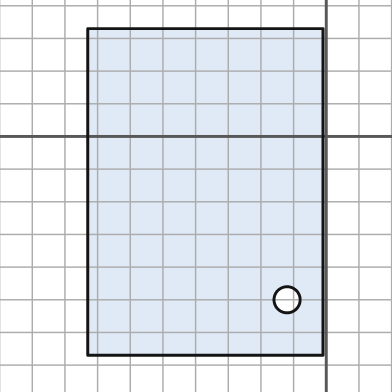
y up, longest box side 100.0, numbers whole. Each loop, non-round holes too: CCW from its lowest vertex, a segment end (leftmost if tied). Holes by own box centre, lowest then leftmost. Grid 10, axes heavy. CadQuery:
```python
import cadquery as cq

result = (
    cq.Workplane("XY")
    .moveTo(-73.0, -67.0)
    .lineTo(-1.0, -67.0)
    .lineTo(-1.0, 33.0)
    .lineTo(-73.0, 33.0)
    .close()
    .moveTo(-12.0, -50.0)
    .circle(4.0)
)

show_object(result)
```